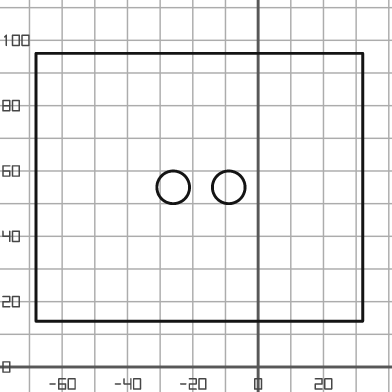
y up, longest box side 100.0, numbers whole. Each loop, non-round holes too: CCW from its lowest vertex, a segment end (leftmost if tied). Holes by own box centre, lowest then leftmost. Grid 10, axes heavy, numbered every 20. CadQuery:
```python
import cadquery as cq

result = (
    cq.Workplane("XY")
    .moveTo(-68.0, 14.0)
    .lineTo(32.0, 14.0)
    .lineTo(32.0, 96.0)
    .lineTo(-68.0, 96.0)
    .close()
    .moveTo(-26.0, 55.0)
    .circle(5.0)
    .moveTo(-9.0, 55.0)
    .circle(5.0)
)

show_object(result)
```